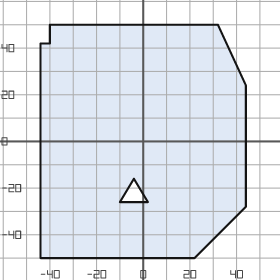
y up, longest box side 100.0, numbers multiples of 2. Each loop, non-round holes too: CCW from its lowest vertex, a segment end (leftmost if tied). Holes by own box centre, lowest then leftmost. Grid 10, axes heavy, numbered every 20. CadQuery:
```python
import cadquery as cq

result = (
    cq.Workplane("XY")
    .moveTo(-44.0, -50.0)
    .lineTo(22.0, -50.0)
    .lineTo(44.0, -28.0)
    .lineTo(44.0, 24.0)
    .lineTo(32.0, 50.0)
    .lineTo(-40.0, 50.0)
    .lineTo(-40.0, 42.0)
    .lineTo(-44.0, 42.0)
    .close()
    .moveTo(-10.0, -26.0)
    .lineTo(2.0, -26.0)
    .lineTo(-4.0, -16.0)
    .close()
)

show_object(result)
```